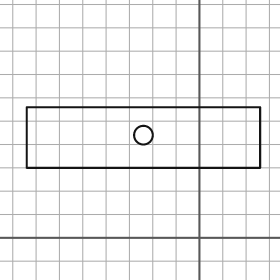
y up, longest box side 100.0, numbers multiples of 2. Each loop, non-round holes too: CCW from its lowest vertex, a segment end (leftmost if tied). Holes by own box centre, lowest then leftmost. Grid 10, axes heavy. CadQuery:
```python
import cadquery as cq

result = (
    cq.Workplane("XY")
    .moveTo(-74.0, 30.0)
    .lineTo(26.0, 30.0)
    .lineTo(26.0, 56.0)
    .lineTo(-74.0, 56.0)
    .close()
    .moveTo(-24.0, 44.0)
    .circle(4.0)
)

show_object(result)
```